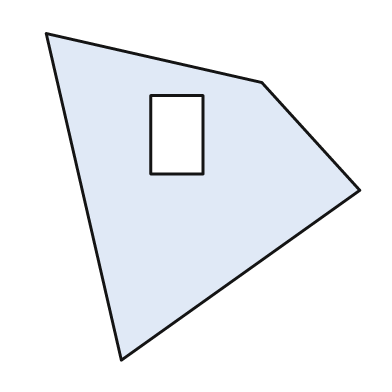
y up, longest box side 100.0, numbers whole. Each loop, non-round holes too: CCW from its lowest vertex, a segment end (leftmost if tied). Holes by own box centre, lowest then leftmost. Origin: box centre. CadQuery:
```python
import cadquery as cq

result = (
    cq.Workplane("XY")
    .moveTo(-25.0, -50.0)
    .lineTo(48.0, 2.0)
    .lineTo(18.0, 35.0)
    .lineTo(-48.0, 50.0)
    .close()
    .moveTo(-16.0, 7.0)
    .lineTo(0.0, 7.0)
    .lineTo(0.0, 31.0)
    .lineTo(-16.0, 31.0)
    .close()
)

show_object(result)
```